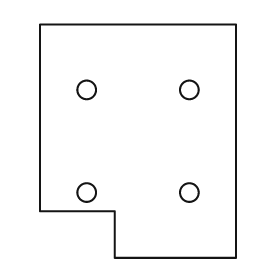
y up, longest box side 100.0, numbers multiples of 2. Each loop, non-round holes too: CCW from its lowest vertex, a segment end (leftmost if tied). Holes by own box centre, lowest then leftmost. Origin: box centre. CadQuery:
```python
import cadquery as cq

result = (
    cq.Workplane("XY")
    .moveTo(-10.0, -50.0)
    .lineTo(42.0, -50.0)
    .lineTo(42.0, 50.0)
    .lineTo(-42.0, 50.0)
    .lineTo(-42.0, -30.0)
    .lineTo(-10.0, -30.0)
    .close()
    .moveTo(-22.0, -22.0)
    .circle(4.0)
    .moveTo(22.0, -22.0)
    .circle(4.0)
    .moveTo(-22.0, 22.0)
    .circle(4.0)
    .moveTo(22.0, 22.0)
    .circle(4.0)
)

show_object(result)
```